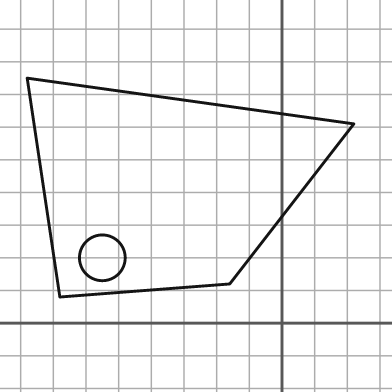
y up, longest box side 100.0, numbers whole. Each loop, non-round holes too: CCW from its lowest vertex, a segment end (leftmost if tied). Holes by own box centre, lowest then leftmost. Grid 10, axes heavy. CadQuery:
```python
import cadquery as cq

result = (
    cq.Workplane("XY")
    .moveTo(-68.0, 8.0)
    .lineTo(-16.0, 12.0)
    .lineTo(22.0, 61.0)
    .lineTo(-78.0, 75.0)
    .close()
    .moveTo(-55.0, 20.0)
    .circle(7.0)
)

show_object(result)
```